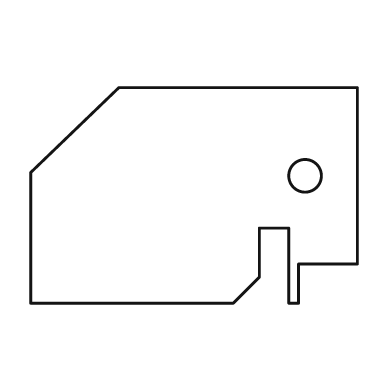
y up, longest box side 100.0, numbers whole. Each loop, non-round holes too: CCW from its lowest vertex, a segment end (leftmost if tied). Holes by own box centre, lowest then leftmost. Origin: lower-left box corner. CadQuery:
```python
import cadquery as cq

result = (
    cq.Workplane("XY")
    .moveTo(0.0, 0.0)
    .lineTo(62.0, 0.0)
    .lineTo(70.0, 8.0)
    .lineTo(70.0, 23.0)
    .lineTo(79.0, 23.0)
    .lineTo(79.0, 0.0)
    .lineTo(82.0, 0.0)
    .lineTo(82.0, 12.0)
    .lineTo(100.0, 12.0)
    .lineTo(100.0, 66.0)
    .lineTo(27.0, 66.0)
    .lineTo(0.0, 40.0)
    .close()
    .moveTo(84.0, 39.0)
    .circle(5.0)
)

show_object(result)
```